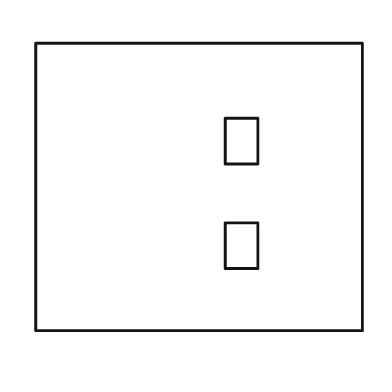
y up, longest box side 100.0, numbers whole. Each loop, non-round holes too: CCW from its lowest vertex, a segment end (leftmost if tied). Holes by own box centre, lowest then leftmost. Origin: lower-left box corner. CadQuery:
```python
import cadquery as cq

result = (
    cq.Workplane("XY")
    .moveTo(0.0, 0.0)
    .lineTo(100.0, 0.0)
    .lineTo(100.0, 88.0)
    .lineTo(0.0, 88.0)
    .close()
    .moveTo(58.0, 19.0)
    .lineTo(68.0, 19.0)
    .lineTo(68.0, 33.0)
    .lineTo(58.0, 33.0)
    .close()
    .moveTo(58.0, 51.0)
    .lineTo(68.0, 51.0)
    .lineTo(68.0, 65.0)
    .lineTo(58.0, 65.0)
    .close()
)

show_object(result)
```